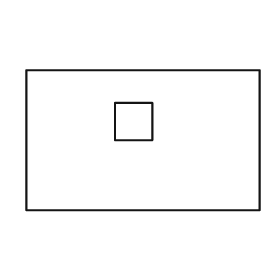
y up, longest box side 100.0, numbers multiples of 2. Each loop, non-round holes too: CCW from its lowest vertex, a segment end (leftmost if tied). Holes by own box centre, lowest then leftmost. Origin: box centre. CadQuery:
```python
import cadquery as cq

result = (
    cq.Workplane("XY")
    .moveTo(-50.0, -30.0)
    .lineTo(50.0, -30.0)
    .lineTo(50.0, 30.0)
    .lineTo(-50.0, 30.0)
    .close()
    .moveTo(-12.0, 0.0)
    .lineTo(4.0, 0.0)
    .lineTo(4.0, 16.0)
    .lineTo(-12.0, 16.0)
    .close()
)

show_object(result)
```